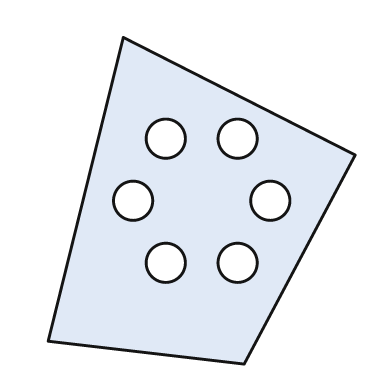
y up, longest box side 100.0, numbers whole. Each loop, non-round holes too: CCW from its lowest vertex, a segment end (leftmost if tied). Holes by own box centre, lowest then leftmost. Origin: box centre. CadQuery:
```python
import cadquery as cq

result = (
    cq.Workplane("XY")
    .moveTo(13.0, -50.0)
    .lineTo(47.0, 14.0)
    .lineTo(-24.0, 50.0)
    .lineTo(-47.0, -43.0)
    .close()
    .moveTo(-11.0, -19.0)
    .circle(6.0)
    .moveTo(11.0, -19.0)
    .circle(6.0)
    .moveTo(-21.0, 0.0)
    .circle(6.0)
    .moveTo(21.0, 0.0)
    .circle(6.0)
    .moveTo(-11.0, 19.0)
    .circle(6.0)
    .moveTo(11.0, 19.0)
    .circle(6.0)
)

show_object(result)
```